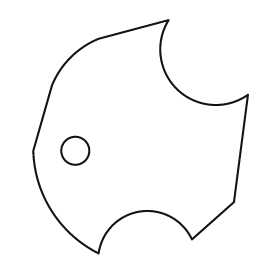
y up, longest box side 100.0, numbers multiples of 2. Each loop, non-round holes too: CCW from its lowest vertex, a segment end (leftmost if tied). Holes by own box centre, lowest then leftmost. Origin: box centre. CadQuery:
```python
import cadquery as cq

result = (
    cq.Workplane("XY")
    .moveTo(-18.0, -50.0)
    .threePointArc((0.0, -32.0), (22.0, -44.0))
    .lineTo(40.0, -28.0)
    .lineTo(46.0, 18.0)
    .threePointArc((16.0, 20.0), (12.0, 50.0))
    .lineTo(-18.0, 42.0)
    .threePointArc((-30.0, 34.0), (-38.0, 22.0))
    .lineTo(-46.0, -6.0)
    .threePointArc((-38.0, -32.0), (-18.0, -50.0))
    .close()
    .moveTo(-28.0, -6.0)
    .circle(6.0)
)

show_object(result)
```